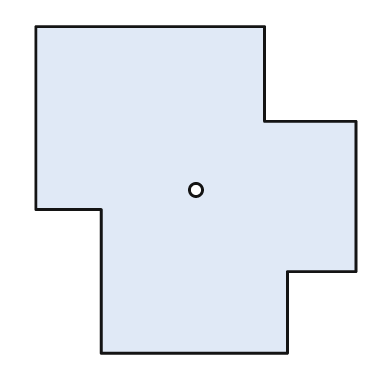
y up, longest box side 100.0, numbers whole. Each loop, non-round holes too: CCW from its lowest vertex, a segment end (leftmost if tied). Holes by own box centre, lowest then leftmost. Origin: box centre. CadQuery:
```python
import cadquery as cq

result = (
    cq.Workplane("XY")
    .moveTo(-29.0, -50.0)
    .lineTo(28.0, -50.0)
    .lineTo(28.0, -25.0)
    .lineTo(49.0, -25.0)
    .lineTo(49.0, 21.0)
    .lineTo(21.0, 21.0)
    .lineTo(21.0, 50.0)
    .lineTo(-49.0, 50.0)
    .lineTo(-49.0, -6.0)
    .lineTo(-29.0, -6.0)
    .close()
    .moveTo(0.0, 0.0)
    .circle(2.0)
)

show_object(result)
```